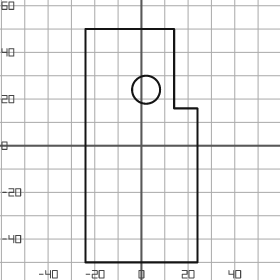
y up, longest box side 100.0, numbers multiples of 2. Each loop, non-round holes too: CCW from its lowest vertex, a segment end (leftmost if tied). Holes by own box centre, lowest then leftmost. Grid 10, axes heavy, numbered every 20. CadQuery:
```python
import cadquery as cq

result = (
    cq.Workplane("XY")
    .moveTo(-24.0, -50.0)
    .lineTo(24.0, -50.0)
    .lineTo(24.0, 16.0)
    .lineTo(14.0, 16.0)
    .lineTo(14.0, 50.0)
    .lineTo(-24.0, 50.0)
    .close()
    .moveTo(2.0, 24.0)
    .circle(6.0)
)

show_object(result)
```